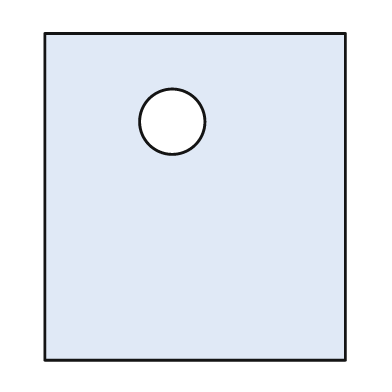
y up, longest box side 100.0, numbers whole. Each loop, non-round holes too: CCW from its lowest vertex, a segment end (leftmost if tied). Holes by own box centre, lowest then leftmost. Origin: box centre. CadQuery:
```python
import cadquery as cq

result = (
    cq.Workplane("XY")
    .moveTo(-46.0, -50.0)
    .lineTo(46.0, -50.0)
    .lineTo(46.0, 50.0)
    .lineTo(-46.0, 50.0)
    .close()
    .moveTo(-7.0, 23.0)
    .circle(10.0)
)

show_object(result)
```